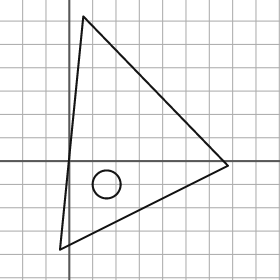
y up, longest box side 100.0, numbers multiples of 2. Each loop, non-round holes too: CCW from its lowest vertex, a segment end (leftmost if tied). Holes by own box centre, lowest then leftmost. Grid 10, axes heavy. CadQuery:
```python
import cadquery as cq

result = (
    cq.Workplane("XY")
    .moveTo(-4.0, -38.0)
    .lineTo(68.0, -2.0)
    .lineTo(6.0, 62.0)
    .close()
    .moveTo(16.0, -10.0)
    .circle(6.0)
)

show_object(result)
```